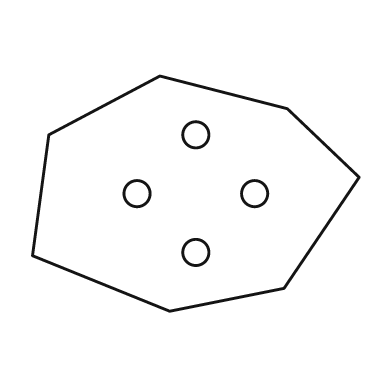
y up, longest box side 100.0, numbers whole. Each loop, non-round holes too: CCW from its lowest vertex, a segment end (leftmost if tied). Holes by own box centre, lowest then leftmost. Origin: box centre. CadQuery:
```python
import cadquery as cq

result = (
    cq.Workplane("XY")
    .moveTo(-8.0, -36.0)
    .lineTo(27.0, -29.0)
    .lineTo(50.0, 5.0)
    .lineTo(28.0, 26.0)
    .lineTo(-11.0, 36.0)
    .lineTo(-45.0, 18.0)
    .lineTo(-50.0, -19.0)
    .close()
    .moveTo(0.0, -18.0)
    .circle(4.0)
    .moveTo(-18.0, 0.0)
    .circle(4.0)
    .moveTo(18.0, 0.0)
    .circle(4.0)
    .moveTo(0.0, 18.0)
    .circle(4.0)
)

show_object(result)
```